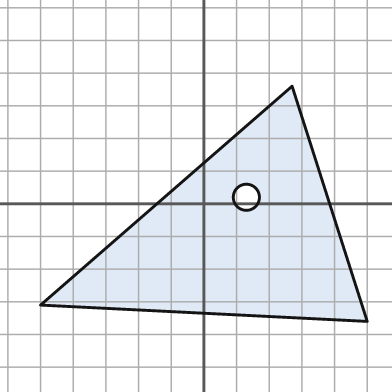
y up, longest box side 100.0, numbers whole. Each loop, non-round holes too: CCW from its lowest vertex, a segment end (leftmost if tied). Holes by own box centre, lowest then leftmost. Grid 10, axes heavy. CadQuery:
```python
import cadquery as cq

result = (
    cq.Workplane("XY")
    .moveTo(50.0, -36.0)
    .lineTo(27.0, 36.0)
    .lineTo(-50.0, -31.0)
    .close()
    .moveTo(13.0, 2.0)
    .circle(4.0)
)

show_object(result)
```